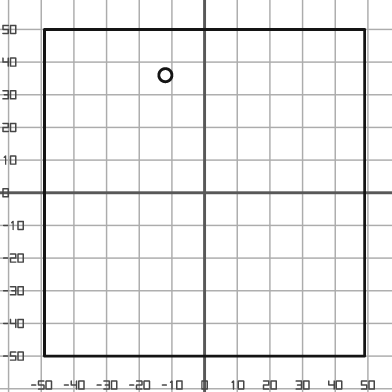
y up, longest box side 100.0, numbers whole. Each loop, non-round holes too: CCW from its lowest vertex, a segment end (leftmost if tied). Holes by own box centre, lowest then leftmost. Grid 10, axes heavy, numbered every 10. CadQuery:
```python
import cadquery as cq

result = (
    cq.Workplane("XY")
    .moveTo(-49.0, -50.0)
    .lineTo(49.0, -50.0)
    .lineTo(49.0, 50.0)
    .lineTo(-49.0, 50.0)
    .close()
    .moveTo(-12.0, 36.0)
    .circle(2.0)
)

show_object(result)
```